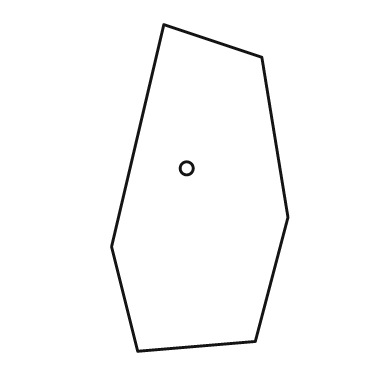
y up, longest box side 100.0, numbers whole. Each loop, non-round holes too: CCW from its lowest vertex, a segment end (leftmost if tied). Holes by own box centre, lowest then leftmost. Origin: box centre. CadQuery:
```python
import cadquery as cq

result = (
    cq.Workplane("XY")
    .moveTo(-19.0, -50.0)
    .lineTo(17.0, -47.0)
    .lineTo(27.0, -9.0)
    .lineTo(19.0, 40.0)
    .lineTo(-11.0, 50.0)
    .lineTo(-27.0, -18.0)
    .close()
    .moveTo(-4.0, 6.0)
    .circle(2.0)
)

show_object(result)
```